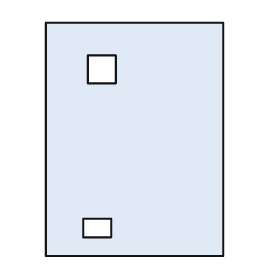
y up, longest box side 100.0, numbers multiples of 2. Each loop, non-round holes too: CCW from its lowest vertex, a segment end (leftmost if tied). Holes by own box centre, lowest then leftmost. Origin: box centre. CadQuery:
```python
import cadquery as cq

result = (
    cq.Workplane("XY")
    .moveTo(-38.0, -50.0)
    .lineTo(38.0, -50.0)
    .lineTo(38.0, 50.0)
    .lineTo(-38.0, 50.0)
    .close()
    .moveTo(-22.0, -42.0)
    .lineTo(-10.0, -42.0)
    .lineTo(-10.0, -34.0)
    .lineTo(-22.0, -34.0)
    .close()
    .moveTo(-20.0, 24.0)
    .lineTo(-8.0, 24.0)
    .lineTo(-8.0, 36.0)
    .lineTo(-20.0, 36.0)
    .close()
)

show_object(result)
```